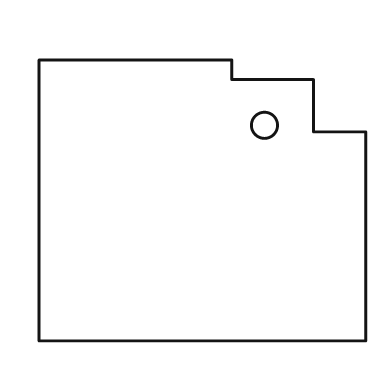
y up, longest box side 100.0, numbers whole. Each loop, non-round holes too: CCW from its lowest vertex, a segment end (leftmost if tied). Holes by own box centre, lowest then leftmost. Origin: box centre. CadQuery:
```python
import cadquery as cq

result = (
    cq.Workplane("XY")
    .moveTo(-50.0, -43.0)
    .lineTo(50.0, -43.0)
    .lineTo(50.0, 21.0)
    .lineTo(34.0, 21.0)
    .lineTo(34.0, 37.0)
    .lineTo(9.0, 37.0)
    .lineTo(9.0, 43.0)
    .lineTo(-50.0, 43.0)
    .close()
    .moveTo(19.0, 23.0)
    .circle(4.0)
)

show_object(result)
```